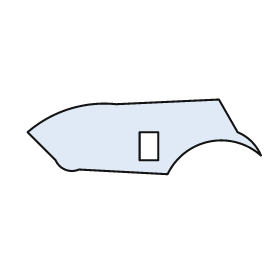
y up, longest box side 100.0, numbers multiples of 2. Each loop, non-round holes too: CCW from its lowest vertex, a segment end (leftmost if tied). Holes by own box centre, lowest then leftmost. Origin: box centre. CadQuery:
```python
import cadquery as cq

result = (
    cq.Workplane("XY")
    .moveTo(10.0, -16.0)
    .threePointArc((28.0, -2.0), (50.0, -8.0))
    .threePointArc((46.0, -2.0), (40.0, 2.0))
    .lineTo(32.0, 16.0)
    .lineTo(-12.0, 14.0)
    .threePointArc((-32.0, 12.0), (-50.0, 2.0))
    .lineTo(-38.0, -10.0)
    .threePointArc((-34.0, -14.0), (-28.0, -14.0))
    .close()
    .moveTo(-2.0, -10.0)
    .lineTo(6.0, -10.0)
    .lineTo(6.0, 2.0)
    .lineTo(-2.0, 2.0)
    .close()
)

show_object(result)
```